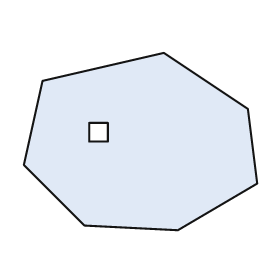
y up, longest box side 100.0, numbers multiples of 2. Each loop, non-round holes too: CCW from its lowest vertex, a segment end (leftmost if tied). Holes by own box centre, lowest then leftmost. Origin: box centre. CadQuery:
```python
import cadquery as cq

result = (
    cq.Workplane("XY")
    .moveTo(16.0, -38.0)
    .lineTo(50.0, -18.0)
    .lineTo(46.0, 14.0)
    .lineTo(10.0, 38.0)
    .lineTo(-42.0, 26.0)
    .lineTo(-50.0, -10.0)
    .lineTo(-24.0, -36.0)
    .close()
    .moveTo(-22.0, 0.0)
    .lineTo(-14.0, 0.0)
    .lineTo(-14.0, 8.0)
    .lineTo(-22.0, 8.0)
    .close()
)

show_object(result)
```